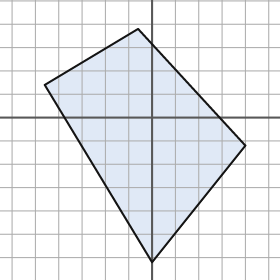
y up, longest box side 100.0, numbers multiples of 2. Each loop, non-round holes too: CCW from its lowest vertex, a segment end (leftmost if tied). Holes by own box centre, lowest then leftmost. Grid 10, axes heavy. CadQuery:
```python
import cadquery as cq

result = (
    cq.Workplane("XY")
    .moveTo(0.0, -62.0)
    .lineTo(40.0, -12.0)
    .lineTo(-6.0, 38.0)
    .lineTo(-46.0, 14.0)
    .close()
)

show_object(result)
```